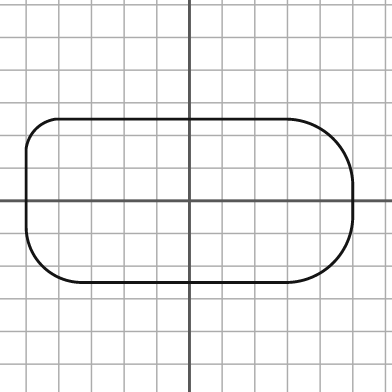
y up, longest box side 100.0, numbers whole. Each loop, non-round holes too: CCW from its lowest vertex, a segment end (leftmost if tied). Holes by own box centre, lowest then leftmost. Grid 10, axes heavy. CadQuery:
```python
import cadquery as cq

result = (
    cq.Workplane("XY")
    .moveTo(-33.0, -25.0)
    .lineTo(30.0, -25.0)
    .threePointArc((44.0, -19.0), (50.0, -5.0))
    .lineTo(50.0, 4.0)
    .threePointArc((44.0, 19.0), (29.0, 25.0))
    .lineTo(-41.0, 25.0)
    .threePointArc((-47.0, 22.0), (-50.0, 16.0))
    .lineTo(-50.0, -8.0)
    .threePointArc((-45.0, -20.0), (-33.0, -25.0))
    .close()
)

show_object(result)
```